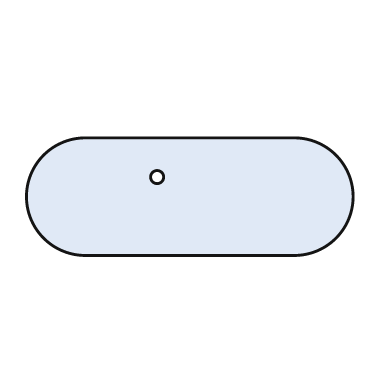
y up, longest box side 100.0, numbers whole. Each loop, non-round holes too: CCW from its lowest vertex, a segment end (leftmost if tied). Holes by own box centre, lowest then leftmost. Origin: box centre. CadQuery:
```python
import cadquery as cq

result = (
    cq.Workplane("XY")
    .moveTo(-32.0, -18.0)
    .lineTo(32.0, -18.0)
    .threePointArc((50.0, 0.0), (32.0, 18.0))
    .lineTo(-32.0, 18.0)
    .threePointArc((-50.0, 0.0), (-32.0, -18.0))
    .close()
    .moveTo(-10.0, 6.0)
    .circle(2.0)
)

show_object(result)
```